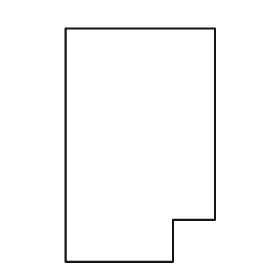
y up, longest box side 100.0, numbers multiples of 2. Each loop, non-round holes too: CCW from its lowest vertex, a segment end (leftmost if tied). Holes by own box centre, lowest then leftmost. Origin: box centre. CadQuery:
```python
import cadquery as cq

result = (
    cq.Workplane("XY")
    .moveTo(-32.0, -50.0)
    .lineTo(14.0, -50.0)
    .lineTo(14.0, -32.0)
    .lineTo(32.0, -32.0)
    .lineTo(32.0, 50.0)
    .lineTo(-32.0, 50.0)
    .close()
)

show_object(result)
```